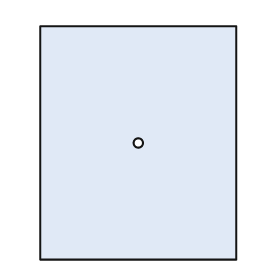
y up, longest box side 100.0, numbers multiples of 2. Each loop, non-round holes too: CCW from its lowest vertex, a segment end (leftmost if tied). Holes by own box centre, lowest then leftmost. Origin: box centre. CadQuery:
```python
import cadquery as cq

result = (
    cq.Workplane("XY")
    .moveTo(-42.0, -50.0)
    .lineTo(42.0, -50.0)
    .lineTo(42.0, 50.0)
    .lineTo(-42.0, 50.0)
    .close()
    .moveTo(0.0, 0.0)
    .circle(2.0)
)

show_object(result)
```